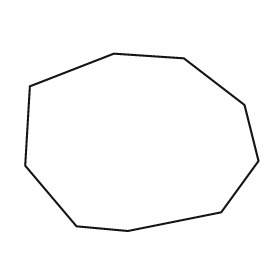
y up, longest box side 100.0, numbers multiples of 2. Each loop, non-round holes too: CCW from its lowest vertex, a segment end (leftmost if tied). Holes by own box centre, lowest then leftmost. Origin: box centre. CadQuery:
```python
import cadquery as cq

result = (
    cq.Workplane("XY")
    .moveTo(-6.0, -38.0)
    .lineTo(34.0, -30.0)
    .lineTo(50.0, -8.0)
    .lineTo(44.0, 16.0)
    .lineTo(18.0, 36.0)
    .lineTo(-12.0, 38.0)
    .lineTo(-48.0, 24.0)
    .lineTo(-50.0, -10.0)
    .lineTo(-28.0, -36.0)
    .close()
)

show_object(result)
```